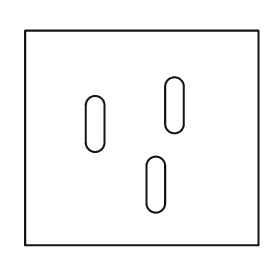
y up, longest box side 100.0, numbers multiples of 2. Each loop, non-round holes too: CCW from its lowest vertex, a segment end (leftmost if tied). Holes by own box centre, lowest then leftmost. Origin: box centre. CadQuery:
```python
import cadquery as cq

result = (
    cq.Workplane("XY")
    .moveTo(-50.0, -46.0)
    .lineTo(50.0, -46.0)
    .lineTo(50.0, 46.0)
    .lineTo(-50.0, 46.0)
    .close()
    .moveTo(2.0, -28.0)
    .threePointArc((6.0, -32.0), (10.0, -28.0))
    .lineTo(10.0, -12.0)
    .threePointArc((6.0, -8.0), (2.0, -12.0))
    .close()
    .moveTo(-24.0, -2.0)
    .threePointArc((-20.0, -6.0), (-16.0, -2.0))
    .lineTo(-16.0, 14.0)
    .threePointArc((-20.0, 18.0), (-24.0, 14.0))
    .close()
    .moveTo(10.0, 6.0)
    .threePointArc((14.0, 2.0), (18.0, 6.0))
    .lineTo(18.0, 22.0)
    .threePointArc((14.0, 26.0), (10.0, 22.0))
    .close()
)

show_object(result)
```